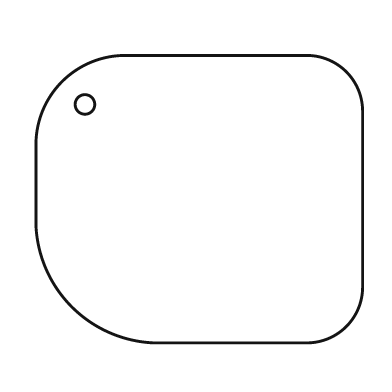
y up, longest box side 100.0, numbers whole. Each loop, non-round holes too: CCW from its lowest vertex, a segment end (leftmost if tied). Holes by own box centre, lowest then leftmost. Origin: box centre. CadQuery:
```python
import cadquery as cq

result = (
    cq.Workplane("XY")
    .moveTo(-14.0, -44.0)
    .lineTo(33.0, -44.0)
    .threePointArc((45.0, -39.0), (50.0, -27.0))
    .lineTo(50.0, 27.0)
    .threePointArc((45.0, 39.0), (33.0, 44.0))
    .lineTo(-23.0, 44.0)
    .threePointArc((-42.0, 36.0), (-50.0, 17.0))
    .lineTo(-50.0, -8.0)
    .threePointArc((-39.0, -33.0), (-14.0, -44.0))
    .close()
    .moveTo(-35.0, 29.0)
    .circle(3.0)
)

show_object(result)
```